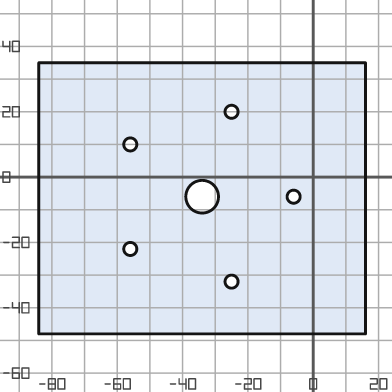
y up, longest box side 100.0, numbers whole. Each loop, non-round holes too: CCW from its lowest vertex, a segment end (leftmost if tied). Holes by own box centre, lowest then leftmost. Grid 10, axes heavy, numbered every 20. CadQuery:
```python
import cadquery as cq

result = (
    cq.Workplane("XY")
    .moveTo(-84.0, -48.0)
    .lineTo(16.0, -48.0)
    .lineTo(16.0, 35.0)
    .lineTo(-84.0, 35.0)
    .close()
    .moveTo(-25.0, -32.0)
    .circle(2.0)
    .moveTo(-56.0, -22.0)
    .circle(2.0)
    .moveTo(-34.0, -6.0)
    .circle(5.0)
    .moveTo(-6.0, -6.0)
    .circle(2.0)
    .moveTo(-56.0, 10.0)
    .circle(2.0)
    .moveTo(-25.0, 20.0)
    .circle(2.0)
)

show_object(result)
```